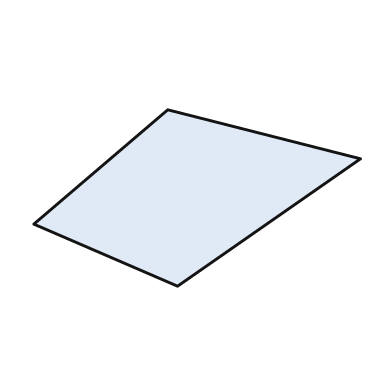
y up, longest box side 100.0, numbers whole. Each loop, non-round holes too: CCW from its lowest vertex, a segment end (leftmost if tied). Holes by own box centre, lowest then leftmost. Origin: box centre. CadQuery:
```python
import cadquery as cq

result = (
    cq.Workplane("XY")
    .moveTo(-6.0, -27.0)
    .lineTo(50.0, 12.0)
    .lineTo(-9.0, 27.0)
    .lineTo(-50.0, -8.0)
    .close()
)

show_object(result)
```